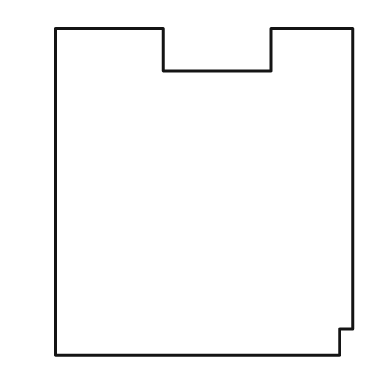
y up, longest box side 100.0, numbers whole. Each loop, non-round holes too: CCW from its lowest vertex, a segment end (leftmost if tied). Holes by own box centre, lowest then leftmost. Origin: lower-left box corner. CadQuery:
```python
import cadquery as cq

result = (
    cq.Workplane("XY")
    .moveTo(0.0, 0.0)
    .lineTo(87.0, 0.0)
    .lineTo(87.0, 8.0)
    .lineTo(91.0, 8.0)
    .lineTo(91.0, 100.0)
    .lineTo(66.0, 100.0)
    .lineTo(66.0, 87.0)
    .lineTo(33.0, 87.0)
    .lineTo(33.0, 100.0)
    .lineTo(0.0, 100.0)
    .close()
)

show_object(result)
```